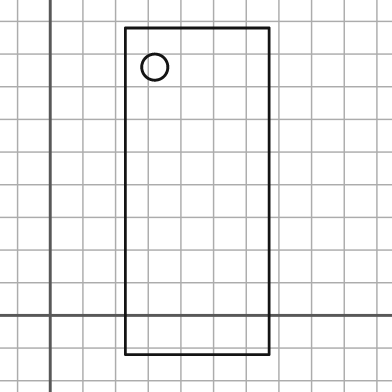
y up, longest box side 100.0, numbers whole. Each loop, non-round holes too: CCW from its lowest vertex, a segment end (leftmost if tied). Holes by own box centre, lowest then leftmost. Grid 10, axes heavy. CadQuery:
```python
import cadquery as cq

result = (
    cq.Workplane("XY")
    .moveTo(23.0, -12.0)
    .lineTo(67.0, -12.0)
    .lineTo(67.0, 88.0)
    .lineTo(23.0, 88.0)
    .close()
    .moveTo(32.0, 76.0)
    .circle(4.0)
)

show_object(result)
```